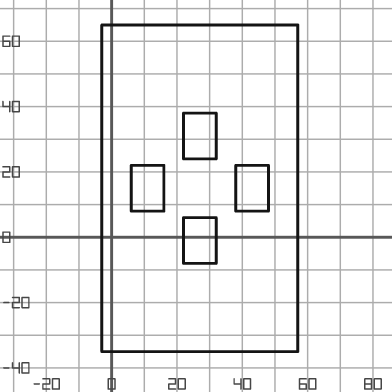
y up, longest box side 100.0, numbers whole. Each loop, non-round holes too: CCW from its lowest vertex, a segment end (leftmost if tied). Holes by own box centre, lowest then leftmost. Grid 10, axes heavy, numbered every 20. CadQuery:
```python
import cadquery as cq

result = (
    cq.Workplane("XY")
    .moveTo(-3.0, -35.0)
    .lineTo(57.0, -35.0)
    .lineTo(57.0, 65.0)
    .lineTo(-3.0, 65.0)
    .close()
    .moveTo(22.0, -8.0)
    .lineTo(32.0, -8.0)
    .lineTo(32.0, 6.0)
    .lineTo(22.0, 6.0)
    .close()
    .moveTo(6.0, 8.0)
    .lineTo(16.0, 8.0)
    .lineTo(16.0, 22.0)
    .lineTo(6.0, 22.0)
    .close()
    .moveTo(38.0, 8.0)
    .lineTo(48.0, 8.0)
    .lineTo(48.0, 22.0)
    .lineTo(38.0, 22.0)
    .close()
    .moveTo(22.0, 24.0)
    .lineTo(32.0, 24.0)
    .lineTo(32.0, 38.0)
    .lineTo(22.0, 38.0)
    .close()
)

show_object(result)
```